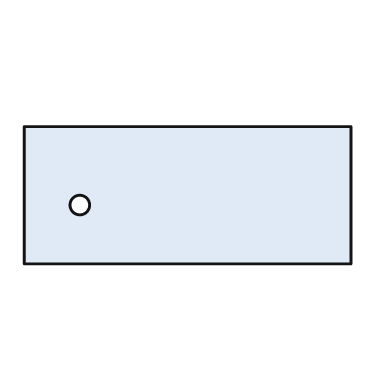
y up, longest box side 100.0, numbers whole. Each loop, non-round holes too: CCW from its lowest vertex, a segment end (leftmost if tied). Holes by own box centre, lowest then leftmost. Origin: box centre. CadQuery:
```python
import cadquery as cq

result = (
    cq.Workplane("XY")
    .moveTo(-50.0, -21.0)
    .lineTo(50.0, -21.0)
    .lineTo(50.0, 21.0)
    .lineTo(-50.0, 21.0)
    .close()
    .moveTo(-33.0, -3.0)
    .circle(3.0)
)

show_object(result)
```